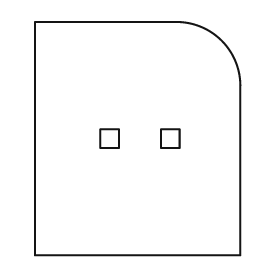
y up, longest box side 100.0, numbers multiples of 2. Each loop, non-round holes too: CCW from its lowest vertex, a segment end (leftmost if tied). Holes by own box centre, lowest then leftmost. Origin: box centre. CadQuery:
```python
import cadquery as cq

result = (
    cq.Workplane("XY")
    .moveTo(-44.0, -50.0)
    .lineTo(44.0, -50.0)
    .lineTo(44.0, 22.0)
    .threePointArc((36.0, 42.0), (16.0, 50.0))
    .lineTo(-44.0, 50.0)
    .close()
    .moveTo(-16.0, -4.0)
    .lineTo(-8.0, -4.0)
    .lineTo(-8.0, 4.0)
    .lineTo(-16.0, 4.0)
    .close()
    .moveTo(10.0, -4.0)
    .lineTo(18.0, -4.0)
    .lineTo(18.0, 4.0)
    .lineTo(10.0, 4.0)
    .close()
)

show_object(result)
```